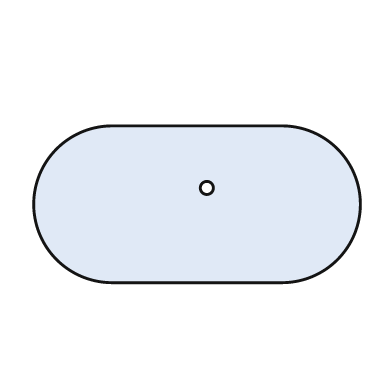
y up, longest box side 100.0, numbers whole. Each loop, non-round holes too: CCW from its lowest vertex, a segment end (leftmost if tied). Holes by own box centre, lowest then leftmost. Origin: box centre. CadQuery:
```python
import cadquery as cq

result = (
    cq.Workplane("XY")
    .moveTo(-26.0, -24.0)
    .lineTo(26.0, -24.0)
    .threePointArc((50.0, 0.0), (26.0, 24.0))
    .lineTo(-26.0, 24.0)
    .threePointArc((-50.0, 0.0), (-26.0, -24.0))
    .close()
    .moveTo(3.0, 5.0)
    .circle(2.0)
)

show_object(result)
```